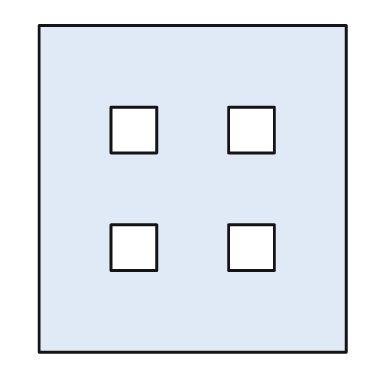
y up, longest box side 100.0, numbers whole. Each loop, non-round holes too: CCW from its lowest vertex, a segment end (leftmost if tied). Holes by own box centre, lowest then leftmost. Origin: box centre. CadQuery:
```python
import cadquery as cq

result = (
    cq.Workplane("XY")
    .moveTo(-47.0, -50.0)
    .lineTo(47.0, -50.0)
    .lineTo(47.0, 50.0)
    .lineTo(-47.0, 50.0)
    .close()
    .moveTo(-25.0, -25.0)
    .lineTo(-11.0, -25.0)
    .lineTo(-11.0, -11.0)
    .lineTo(-25.0, -11.0)
    .close()
    .moveTo(11.0, -25.0)
    .lineTo(25.0, -25.0)
    .lineTo(25.0, -11.0)
    .lineTo(11.0, -11.0)
    .close()
    .moveTo(-25.0, 11.0)
    .lineTo(-11.0, 11.0)
    .lineTo(-11.0, 25.0)
    .lineTo(-25.0, 25.0)
    .close()
    .moveTo(11.0, 11.0)
    .lineTo(25.0, 11.0)
    .lineTo(25.0, 25.0)
    .lineTo(11.0, 25.0)
    .close()
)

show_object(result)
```